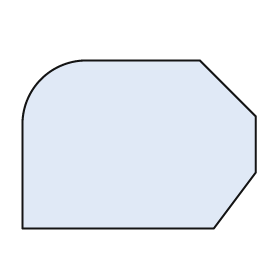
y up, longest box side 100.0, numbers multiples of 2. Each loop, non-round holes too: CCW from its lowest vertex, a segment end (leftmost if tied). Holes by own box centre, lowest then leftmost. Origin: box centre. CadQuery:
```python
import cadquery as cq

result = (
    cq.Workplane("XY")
    .moveTo(-50.0, -36.0)
    .lineTo(32.0, -36.0)
    .lineTo(50.0, -12.0)
    .lineTo(50.0, 12.0)
    .lineTo(26.0, 36.0)
    .lineTo(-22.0, 36.0)
    .threePointArc((-42.0, 28.0), (-50.0, 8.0))
    .close()
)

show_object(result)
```